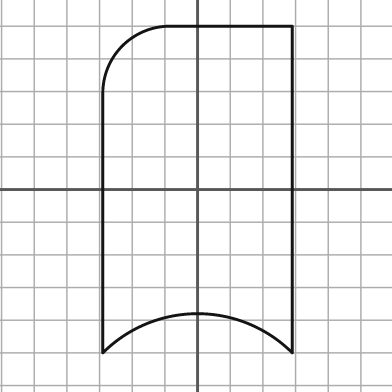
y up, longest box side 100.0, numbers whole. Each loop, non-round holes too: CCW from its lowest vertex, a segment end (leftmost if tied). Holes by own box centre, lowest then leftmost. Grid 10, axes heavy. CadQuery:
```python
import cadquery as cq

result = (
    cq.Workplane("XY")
    .moveTo(-29.0, -50.0)
    .threePointArc((0.0, -38.0), (29.0, -50.0))
    .lineTo(29.0, 50.0)
    .lineTo(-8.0, 50.0)
    .threePointArc((-23.0, 44.0), (-29.0, 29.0))
    .close()
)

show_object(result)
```